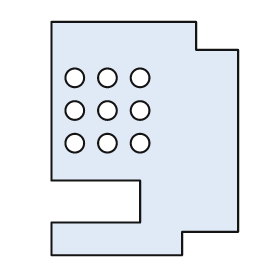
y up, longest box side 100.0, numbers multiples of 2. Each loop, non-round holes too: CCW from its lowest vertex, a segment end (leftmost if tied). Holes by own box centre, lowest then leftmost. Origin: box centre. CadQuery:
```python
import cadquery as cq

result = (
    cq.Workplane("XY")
    .moveTo(-40.0, -50.0)
    .lineTo(16.0, -50.0)
    .lineTo(16.0, -40.0)
    .lineTo(40.0, -40.0)
    .lineTo(40.0, 38.0)
    .lineTo(22.0, 38.0)
    .lineTo(22.0, 50.0)
    .lineTo(-40.0, 50.0)
    .lineTo(-40.0, -18.0)
    .lineTo(-2.0, -18.0)
    .lineTo(-2.0, -36.0)
    .lineTo(-40.0, -36.0)
    .close()
    .moveTo(-30.0, -2.0)
    .circle(4.0)
    .moveTo(-16.0, -2.0)
    .circle(4.0)
    .moveTo(-2.0, -2.0)
    .circle(4.0)
    .moveTo(-30.0, 12.0)
    .circle(4.0)
    .moveTo(-16.0, 12.0)
    .circle(4.0)
    .moveTo(-2.0, 12.0)
    .circle(4.0)
    .moveTo(-30.0, 26.0)
    .circle(4.0)
    .moveTo(-16.0, 26.0)
    .circle(4.0)
    .moveTo(-2.0, 26.0)
    .circle(4.0)
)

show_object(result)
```